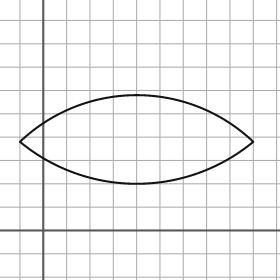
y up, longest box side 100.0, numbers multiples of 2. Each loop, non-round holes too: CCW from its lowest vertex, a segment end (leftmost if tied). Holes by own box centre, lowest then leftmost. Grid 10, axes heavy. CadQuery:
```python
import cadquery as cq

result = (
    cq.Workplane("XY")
    .moveTo(-10.0, 38.0)
    .threePointArc((40.0, 20.0), (90.0, 38.0))
    .threePointArc((40.0, 58.0), (-10.0, 38.0))
    .close()
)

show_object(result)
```